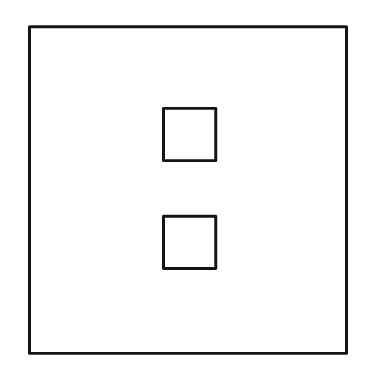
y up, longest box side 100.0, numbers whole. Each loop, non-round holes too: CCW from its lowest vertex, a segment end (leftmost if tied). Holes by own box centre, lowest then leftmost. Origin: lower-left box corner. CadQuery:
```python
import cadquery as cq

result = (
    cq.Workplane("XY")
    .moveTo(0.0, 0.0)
    .lineTo(97.0, 0.0)
    .lineTo(97.0, 100.0)
    .lineTo(0.0, 100.0)
    .close()
    .moveTo(41.0, 26.0)
    .lineTo(57.0, 26.0)
    .lineTo(57.0, 42.0)
    .lineTo(41.0, 42.0)
    .close()
    .moveTo(41.0, 59.0)
    .lineTo(57.0, 59.0)
    .lineTo(57.0, 75.0)
    .lineTo(41.0, 75.0)
    .close()
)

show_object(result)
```